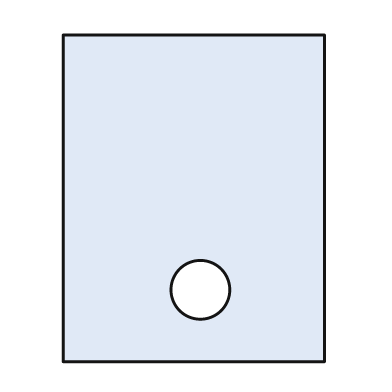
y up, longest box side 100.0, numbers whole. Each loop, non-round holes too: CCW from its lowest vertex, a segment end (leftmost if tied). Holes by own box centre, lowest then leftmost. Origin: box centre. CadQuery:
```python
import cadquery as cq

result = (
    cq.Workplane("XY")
    .moveTo(-40.0, -50.0)
    .lineTo(40.0, -50.0)
    .lineTo(40.0, 50.0)
    .lineTo(-40.0, 50.0)
    .close()
    .moveTo(2.0, -28.0)
    .circle(9.0)
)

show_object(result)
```